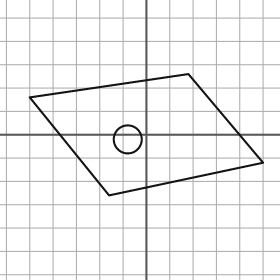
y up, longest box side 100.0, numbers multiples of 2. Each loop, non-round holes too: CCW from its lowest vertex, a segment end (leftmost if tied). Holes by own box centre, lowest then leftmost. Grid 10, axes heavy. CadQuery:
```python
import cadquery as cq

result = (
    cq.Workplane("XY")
    .moveTo(-16.0, -26.0)
    .lineTo(50.0, -12.0)
    .lineTo(18.0, 26.0)
    .lineTo(-50.0, 16.0)
    .close()
    .moveTo(-8.0, -2.0)
    .circle(6.0)
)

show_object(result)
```